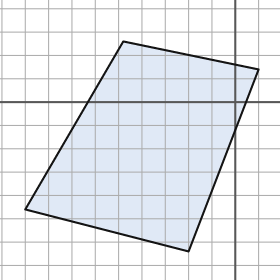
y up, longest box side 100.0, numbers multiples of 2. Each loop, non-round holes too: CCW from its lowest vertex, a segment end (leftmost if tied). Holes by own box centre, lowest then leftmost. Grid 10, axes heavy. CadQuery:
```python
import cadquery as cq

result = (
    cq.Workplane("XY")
    .moveTo(-20.0, -64.0)
    .lineTo(10.0, 14.0)
    .lineTo(-48.0, 26.0)
    .lineTo(-90.0, -46.0)
    .close()
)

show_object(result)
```